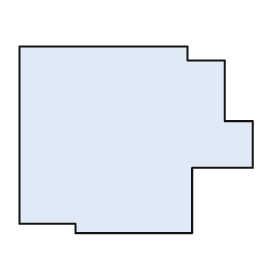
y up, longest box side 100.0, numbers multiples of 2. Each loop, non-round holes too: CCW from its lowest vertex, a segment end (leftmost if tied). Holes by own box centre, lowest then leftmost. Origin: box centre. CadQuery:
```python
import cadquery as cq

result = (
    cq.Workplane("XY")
    .moveTo(-26.0, -40.0)
    .lineTo(24.0, -40.0)
    .lineTo(24.0, -12.0)
    .lineTo(50.0, -12.0)
    .lineTo(50.0, 8.0)
    .lineTo(38.0, 8.0)
    .lineTo(38.0, 34.0)
    .lineTo(22.0, 34.0)
    .lineTo(22.0, 40.0)
    .lineTo(-50.0, 40.0)
    .lineTo(-50.0, -36.0)
    .lineTo(-26.0, -36.0)
    .close()
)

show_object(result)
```